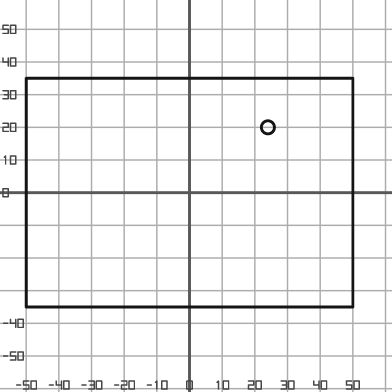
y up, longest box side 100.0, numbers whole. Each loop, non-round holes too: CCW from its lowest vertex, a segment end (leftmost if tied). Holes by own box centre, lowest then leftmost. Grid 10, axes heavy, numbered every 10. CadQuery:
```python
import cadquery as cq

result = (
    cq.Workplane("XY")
    .moveTo(-50.0, -35.0)
    .lineTo(50.0, -35.0)
    .lineTo(50.0, 35.0)
    .lineTo(-50.0, 35.0)
    .close()
    .moveTo(24.0, 20.0)
    .circle(2.0)
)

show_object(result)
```